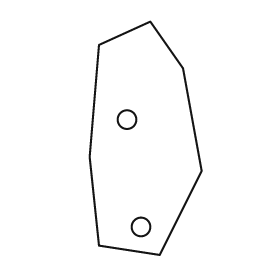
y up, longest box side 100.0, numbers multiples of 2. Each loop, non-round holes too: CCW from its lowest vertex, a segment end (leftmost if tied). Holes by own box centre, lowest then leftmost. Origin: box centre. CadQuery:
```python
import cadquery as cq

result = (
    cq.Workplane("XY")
    .moveTo(6.0, -50.0)
    .lineTo(24.0, -14.0)
    .lineTo(16.0, 30.0)
    .lineTo(2.0, 50.0)
    .lineTo(-20.0, 40.0)
    .lineTo(-24.0, -8.0)
    .lineTo(-20.0, -46.0)
    .close()
    .moveTo(-2.0, -38.0)
    .circle(4.0)
    .moveTo(-8.0, 8.0)
    .circle(4.0)
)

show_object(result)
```